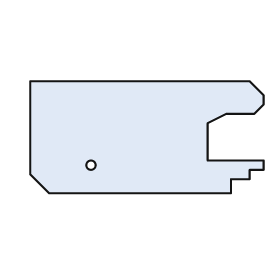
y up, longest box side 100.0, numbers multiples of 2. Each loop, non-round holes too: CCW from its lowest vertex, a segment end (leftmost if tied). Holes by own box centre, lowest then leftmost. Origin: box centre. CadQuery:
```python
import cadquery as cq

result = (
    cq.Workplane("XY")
    .moveTo(-42.0, -24.0)
    .lineTo(36.0, -24.0)
    .lineTo(36.0, -18.0)
    .lineTo(44.0, -18.0)
    .lineTo(44.0, -14.0)
    .lineTo(50.0, -14.0)
    .lineTo(50.0, -10.0)
    .lineTo(26.0, -10.0)
    .lineTo(26.0, 6.0)
    .lineTo(34.0, 10.0)
    .lineTo(46.0, 10.0)
    .lineTo(50.0, 14.0)
    .lineTo(50.0, 18.0)
    .lineTo(44.0, 24.0)
    .lineTo(-50.0, 24.0)
    .lineTo(-50.0, -16.0)
    .close()
    .moveTo(-24.0, -12.0)
    .circle(2.0)
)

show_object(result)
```